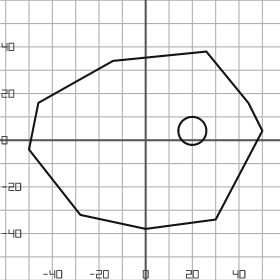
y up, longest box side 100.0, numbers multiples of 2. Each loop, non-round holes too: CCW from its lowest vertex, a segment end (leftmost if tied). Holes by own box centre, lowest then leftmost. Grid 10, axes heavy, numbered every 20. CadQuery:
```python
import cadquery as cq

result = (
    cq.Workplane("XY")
    .moveTo(0.0, -38.0)
    .lineTo(30.0, -34.0)
    .lineTo(50.0, 4.0)
    .lineTo(44.0, 16.0)
    .lineTo(26.0, 38.0)
    .lineTo(-14.0, 34.0)
    .lineTo(-46.0, 16.0)
    .lineTo(-50.0, -4.0)
    .lineTo(-28.0, -32.0)
    .close()
    .moveTo(20.0, 4.0)
    .circle(6.0)
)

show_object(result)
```